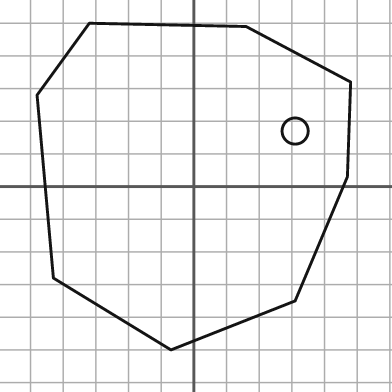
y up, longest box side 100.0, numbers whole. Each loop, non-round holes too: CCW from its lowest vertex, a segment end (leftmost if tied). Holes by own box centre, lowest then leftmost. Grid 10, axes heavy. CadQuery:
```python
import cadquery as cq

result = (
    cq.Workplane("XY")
    .moveTo(-7.0, -50.0)
    .lineTo(31.0, -35.0)
    .lineTo(47.0, 3.0)
    .lineTo(48.0, 32.0)
    .lineTo(16.0, 49.0)
    .lineTo(-32.0, 50.0)
    .lineTo(-48.0, 28.0)
    .lineTo(-43.0, -28.0)
    .close()
    .moveTo(31.0, 17.0)
    .circle(4.0)
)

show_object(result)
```